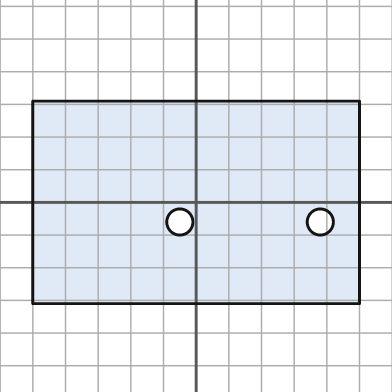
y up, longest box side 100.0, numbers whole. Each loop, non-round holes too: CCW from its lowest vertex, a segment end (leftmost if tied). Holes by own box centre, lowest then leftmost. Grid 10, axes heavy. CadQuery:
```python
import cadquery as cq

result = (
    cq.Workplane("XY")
    .moveTo(-50.0, -31.0)
    .lineTo(50.0, -31.0)
    .lineTo(50.0, 31.0)
    .lineTo(-50.0, 31.0)
    .close()
    .moveTo(-5.0, -6.0)
    .circle(4.0)
    .moveTo(38.0, -6.0)
    .circle(4.0)
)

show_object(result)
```